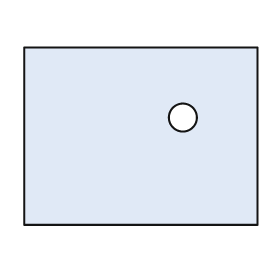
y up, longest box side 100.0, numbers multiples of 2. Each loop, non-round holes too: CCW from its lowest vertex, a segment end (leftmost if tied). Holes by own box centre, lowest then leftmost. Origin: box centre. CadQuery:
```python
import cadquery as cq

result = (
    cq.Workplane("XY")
    .moveTo(-50.0, -38.0)
    .lineTo(50.0, -38.0)
    .lineTo(50.0, 38.0)
    .lineTo(-50.0, 38.0)
    .close()
    .moveTo(18.0, 8.0)
    .circle(6.0)
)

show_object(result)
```